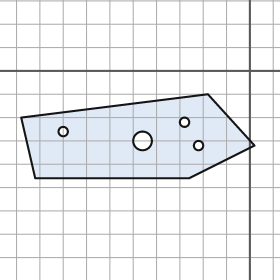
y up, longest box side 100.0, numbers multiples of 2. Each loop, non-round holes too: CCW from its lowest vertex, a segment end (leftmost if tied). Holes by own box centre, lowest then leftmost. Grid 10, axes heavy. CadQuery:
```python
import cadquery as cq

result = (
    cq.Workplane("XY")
    .moveTo(-92.0, -46.0)
    .lineTo(-26.0, -46.0)
    .lineTo(2.0, -32.0)
    .lineTo(-18.0, -10.0)
    .lineTo(-98.0, -20.0)
    .close()
    .moveTo(-22.0, -32.0)
    .circle(2.0)
    .moveTo(-46.0, -30.0)
    .circle(4.0)
    .moveTo(-80.0, -26.0)
    .circle(2.0)
    .moveTo(-28.0, -22.0)
    .circle(2.0)
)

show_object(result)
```